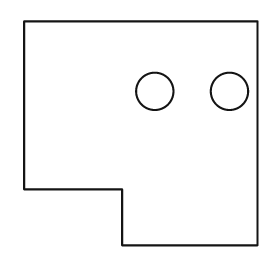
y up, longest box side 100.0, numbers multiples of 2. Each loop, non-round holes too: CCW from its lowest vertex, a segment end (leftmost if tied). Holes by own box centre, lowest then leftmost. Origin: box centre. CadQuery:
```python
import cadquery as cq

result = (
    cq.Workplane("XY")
    .moveTo(-8.0, -48.0)
    .lineTo(50.0, -48.0)
    .lineTo(50.0, 48.0)
    .lineTo(-50.0, 48.0)
    .lineTo(-50.0, -24.0)
    .lineTo(-8.0, -24.0)
    .close()
    .moveTo(6.0, 18.0)
    .circle(8.0)
    .moveTo(38.0, 18.0)
    .circle(8.0)
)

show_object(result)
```